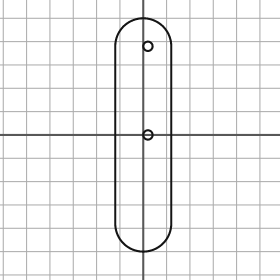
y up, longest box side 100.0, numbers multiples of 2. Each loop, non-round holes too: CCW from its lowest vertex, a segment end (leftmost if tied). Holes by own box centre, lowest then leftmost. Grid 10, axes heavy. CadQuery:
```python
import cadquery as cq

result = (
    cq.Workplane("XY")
    .moveTo(-12.0, -38.0)
    .threePointArc((0.0, -50.0), (12.0, -38.0))
    .lineTo(12.0, 38.0)
    .threePointArc((0.0, 50.0), (-12.0, 38.0))
    .close()
    .moveTo(2.0, 0.0)
    .circle(2.0)
    .moveTo(2.0, 38.0)
    .circle(2.0)
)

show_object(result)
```